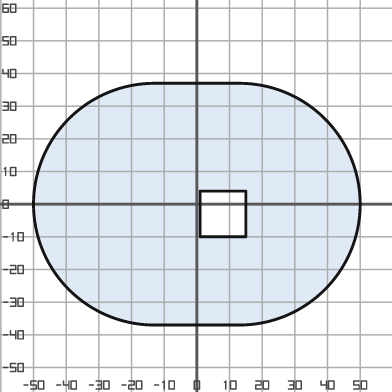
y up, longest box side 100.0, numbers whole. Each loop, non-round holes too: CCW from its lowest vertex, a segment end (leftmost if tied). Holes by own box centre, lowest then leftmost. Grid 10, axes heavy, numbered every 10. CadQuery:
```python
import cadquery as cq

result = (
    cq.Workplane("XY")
    .moveTo(-13.0, -37.0)
    .lineTo(13.0, -37.0)
    .threePointArc((50.0, 0.0), (13.0, 37.0))
    .lineTo(-13.0, 37.0)
    .threePointArc((-50.0, 0.0), (-13.0, -37.0))
    .close()
    .moveTo(1.0, -10.0)
    .lineTo(15.0, -10.0)
    .lineTo(15.0, 4.0)
    .lineTo(1.0, 4.0)
    .close()
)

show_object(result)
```